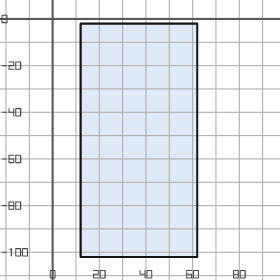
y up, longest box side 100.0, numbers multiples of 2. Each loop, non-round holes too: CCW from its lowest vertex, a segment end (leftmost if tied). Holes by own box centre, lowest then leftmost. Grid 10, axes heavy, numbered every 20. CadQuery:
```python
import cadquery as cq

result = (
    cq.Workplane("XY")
    .moveTo(12.0, -102.0)
    .lineTo(62.0, -102.0)
    .lineTo(62.0, -2.0)
    .lineTo(12.0, -2.0)
    .close()
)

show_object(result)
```